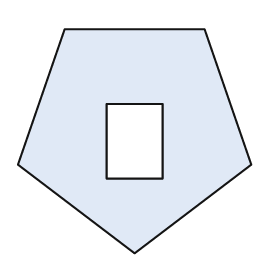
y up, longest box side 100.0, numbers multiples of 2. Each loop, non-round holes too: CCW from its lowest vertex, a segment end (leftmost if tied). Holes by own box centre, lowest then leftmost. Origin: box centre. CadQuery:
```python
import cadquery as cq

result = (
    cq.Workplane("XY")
    .moveTo(0.0, -48.0)
    .lineTo(50.0, -10.0)
    .lineTo(30.0, 48.0)
    .lineTo(-30.0, 48.0)
    .lineTo(-50.0, -10.0)
    .close()
    .moveTo(-12.0, -16.0)
    .lineTo(12.0, -16.0)
    .lineTo(12.0, 16.0)
    .lineTo(-12.0, 16.0)
    .close()
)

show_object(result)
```